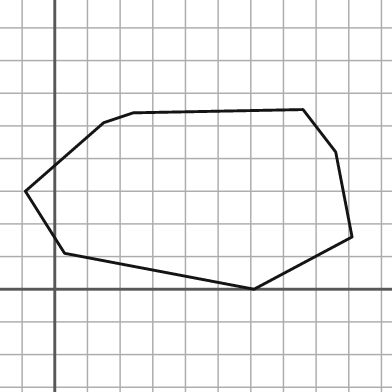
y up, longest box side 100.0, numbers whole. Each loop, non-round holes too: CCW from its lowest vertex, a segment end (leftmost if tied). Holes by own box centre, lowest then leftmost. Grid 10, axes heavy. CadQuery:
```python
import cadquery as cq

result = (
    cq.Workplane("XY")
    .moveTo(61.0, 0.0)
    .lineTo(91.0, 16.0)
    .lineTo(86.0, 42.0)
    .lineTo(76.0, 55.0)
    .lineTo(24.0, 54.0)
    .lineTo(15.0, 51.0)
    .lineTo(-9.0, 30.0)
    .lineTo(3.0, 11.0)
    .close()
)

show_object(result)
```